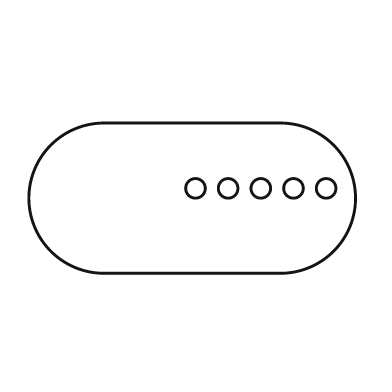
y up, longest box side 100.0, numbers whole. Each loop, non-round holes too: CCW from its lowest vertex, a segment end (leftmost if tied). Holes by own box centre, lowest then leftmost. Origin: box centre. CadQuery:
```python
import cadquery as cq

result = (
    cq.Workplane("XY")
    .moveTo(-27.0, -23.0)
    .lineTo(27.0, -23.0)
    .threePointArc((50.0, 0.0), (27.0, 23.0))
    .lineTo(-27.0, 23.0)
    .threePointArc((-50.0, 0.0), (-27.0, -23.0))
    .close()
    .moveTo(1.0, 3.0)
    .circle(3.0)
    .moveTo(11.0, 3.0)
    .circle(3.0)
    .moveTo(21.0, 3.0)
    .circle(3.0)
    .moveTo(31.0, 3.0)
    .circle(3.0)
    .moveTo(41.0, 3.0)
    .circle(3.0)
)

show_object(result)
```